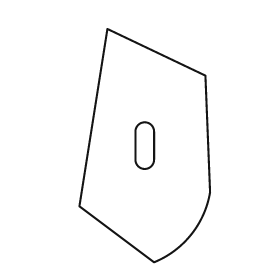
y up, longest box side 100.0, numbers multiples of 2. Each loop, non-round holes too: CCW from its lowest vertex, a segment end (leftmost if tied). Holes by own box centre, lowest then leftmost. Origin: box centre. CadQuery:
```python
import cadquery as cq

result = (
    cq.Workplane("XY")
    .moveTo(4.0, -50.0)
    .threePointArc((20.0, -38.0), (28.0, -20.0))
    .lineTo(26.0, 30.0)
    .lineTo(-16.0, 50.0)
    .lineTo(-28.0, -26.0)
    .close()
    .moveTo(-4.0, -6.0)
    .threePointArc((0.0, -10.0), (4.0, -6.0))
    .lineTo(4.0, 6.0)
    .threePointArc((0.0, 10.0), (-4.0, 6.0))
    .close()
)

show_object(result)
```